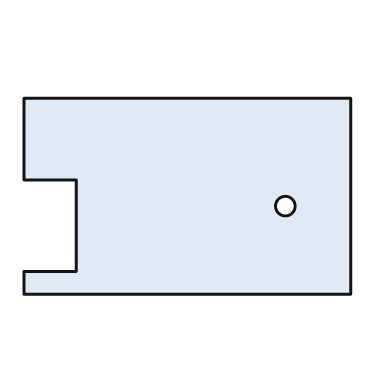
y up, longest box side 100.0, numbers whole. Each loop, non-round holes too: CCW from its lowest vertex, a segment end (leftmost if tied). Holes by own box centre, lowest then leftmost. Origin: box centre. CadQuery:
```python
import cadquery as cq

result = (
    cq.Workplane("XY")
    .moveTo(-50.0, -30.0)
    .lineTo(50.0, -30.0)
    .lineTo(50.0, 30.0)
    .lineTo(-50.0, 30.0)
    .lineTo(-50.0, 5.0)
    .lineTo(-34.0, 5.0)
    .lineTo(-34.0, -23.0)
    .lineTo(-50.0, -23.0)
    .close()
    .moveTo(30.0, -3.0)
    .circle(3.0)
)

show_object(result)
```